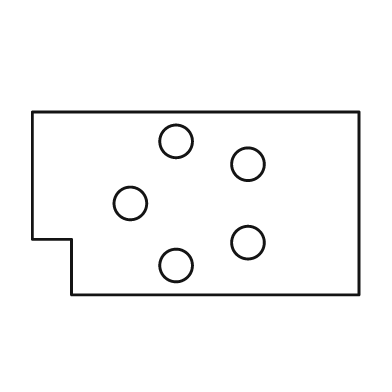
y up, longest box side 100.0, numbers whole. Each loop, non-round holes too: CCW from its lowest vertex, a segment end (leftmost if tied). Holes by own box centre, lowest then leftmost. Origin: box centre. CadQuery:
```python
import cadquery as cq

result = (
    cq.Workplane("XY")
    .moveTo(-38.0, -28.0)
    .lineTo(50.0, -28.0)
    .lineTo(50.0, 28.0)
    .lineTo(-50.0, 28.0)
    .lineTo(-50.0, -11.0)
    .lineTo(-38.0, -11.0)
    .close()
    .moveTo(-6.0, -19.0)
    .circle(5.0)
    .moveTo(16.0, -12.0)
    .circle(5.0)
    .moveTo(-20.0, 0.0)
    .circle(5.0)
    .moveTo(16.0, 12.0)
    .circle(5.0)
    .moveTo(-6.0, 19.0)
    .circle(5.0)
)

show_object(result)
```